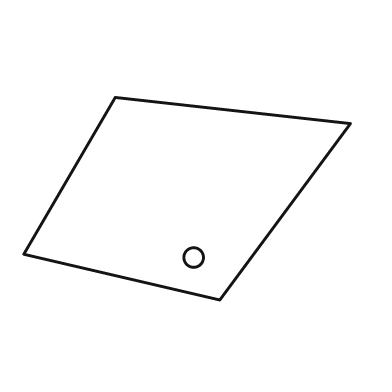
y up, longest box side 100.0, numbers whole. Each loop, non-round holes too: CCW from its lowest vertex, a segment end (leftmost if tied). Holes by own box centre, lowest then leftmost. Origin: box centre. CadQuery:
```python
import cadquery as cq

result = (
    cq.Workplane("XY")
    .moveTo(10.0, -31.0)
    .lineTo(50.0, 23.0)
    .lineTo(-22.0, 31.0)
    .lineTo(-50.0, -17.0)
    .close()
    .moveTo(2.0, -18.0)
    .circle(3.0)
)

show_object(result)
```